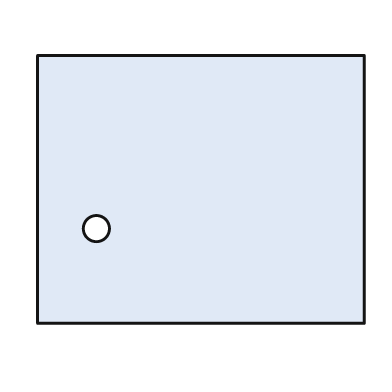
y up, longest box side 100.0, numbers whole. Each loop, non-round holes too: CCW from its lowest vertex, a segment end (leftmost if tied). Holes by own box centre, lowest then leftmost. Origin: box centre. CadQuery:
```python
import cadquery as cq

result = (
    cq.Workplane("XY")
    .moveTo(-50.0, -41.0)
    .lineTo(50.0, -41.0)
    .lineTo(50.0, 41.0)
    .lineTo(-50.0, 41.0)
    .close()
    .moveTo(-32.0, -12.0)
    .circle(4.0)
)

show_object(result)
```